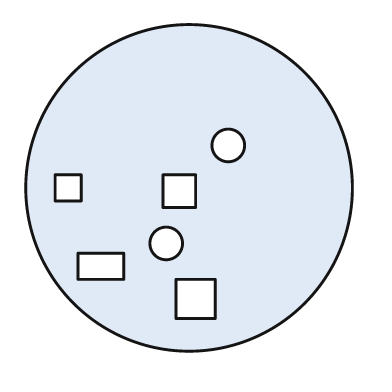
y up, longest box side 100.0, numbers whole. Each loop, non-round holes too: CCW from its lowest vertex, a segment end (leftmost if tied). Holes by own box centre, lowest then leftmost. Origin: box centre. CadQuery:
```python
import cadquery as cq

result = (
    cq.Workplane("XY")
    .moveTo(0.0, 0.0)
    .circle(50.0)
    .moveTo(-4.0, -40.0)
    .lineTo(8.0, -40.0)
    .lineTo(8.0, -28.0)
    .lineTo(-4.0, -28.0)
    .close()
    .moveTo(-34.0, -28.0)
    .lineTo(-20.0, -28.0)
    .lineTo(-20.0, -20.0)
    .lineTo(-34.0, -20.0)
    .close()
    .moveTo(-7.0, -17.0)
    .circle(5.0)
    .moveTo(-8.0, -6.0)
    .lineTo(2.0, -6.0)
    .lineTo(2.0, 4.0)
    .lineTo(-8.0, 4.0)
    .close()
    .moveTo(-41.0, -4.0)
    .lineTo(-33.0, -4.0)
    .lineTo(-33.0, 4.0)
    .lineTo(-41.0, 4.0)
    .close()
    .moveTo(12.0, 13.0)
    .circle(5.0)
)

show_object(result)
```